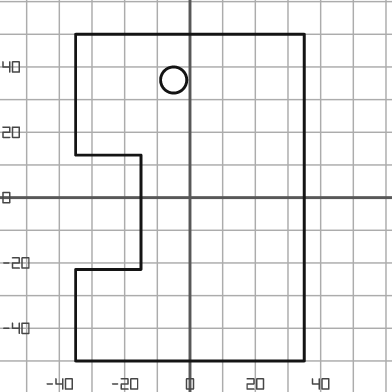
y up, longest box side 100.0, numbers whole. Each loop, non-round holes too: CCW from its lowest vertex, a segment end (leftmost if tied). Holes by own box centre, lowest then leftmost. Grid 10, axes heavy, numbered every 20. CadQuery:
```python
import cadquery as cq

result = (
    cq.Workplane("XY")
    .moveTo(-35.0, -50.0)
    .lineTo(35.0, -50.0)
    .lineTo(35.0, 50.0)
    .lineTo(-35.0, 50.0)
    .lineTo(-35.0, 13.0)
    .lineTo(-15.0, 13.0)
    .lineTo(-15.0, -22.0)
    .lineTo(-35.0, -22.0)
    .close()
    .moveTo(-5.0, 36.0)
    .circle(4.0)
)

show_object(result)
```